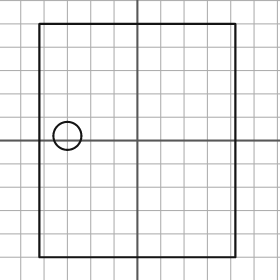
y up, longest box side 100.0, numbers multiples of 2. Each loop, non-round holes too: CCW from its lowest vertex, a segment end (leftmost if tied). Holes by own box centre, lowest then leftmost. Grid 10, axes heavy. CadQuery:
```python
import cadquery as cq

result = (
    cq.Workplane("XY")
    .moveTo(-42.0, -50.0)
    .lineTo(42.0, -50.0)
    .lineTo(42.0, 50.0)
    .lineTo(-42.0, 50.0)
    .close()
    .moveTo(-30.0, 2.0)
    .circle(6.0)
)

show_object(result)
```